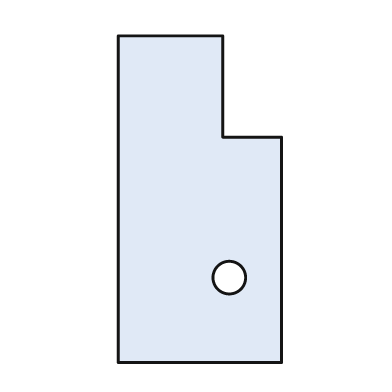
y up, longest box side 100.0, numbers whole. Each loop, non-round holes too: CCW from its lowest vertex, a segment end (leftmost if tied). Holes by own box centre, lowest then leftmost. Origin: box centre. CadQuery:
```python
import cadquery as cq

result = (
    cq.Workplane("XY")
    .moveTo(-25.0, -50.0)
    .lineTo(25.0, -50.0)
    .lineTo(25.0, 19.0)
    .lineTo(7.0, 19.0)
    .lineTo(7.0, 50.0)
    .lineTo(-25.0, 50.0)
    .close()
    .moveTo(9.0, -24.0)
    .circle(5.0)
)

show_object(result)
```